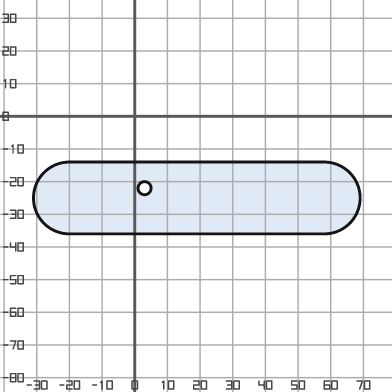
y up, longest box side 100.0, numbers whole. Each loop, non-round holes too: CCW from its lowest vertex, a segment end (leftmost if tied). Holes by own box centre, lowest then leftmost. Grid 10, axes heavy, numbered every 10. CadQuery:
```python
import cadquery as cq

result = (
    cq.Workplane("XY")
    .moveTo(-20.0, -36.0)
    .lineTo(58.0, -36.0)
    .threePointArc((69.0, -25.0), (58.0, -14.0))
    .lineTo(-20.0, -14.0)
    .threePointArc((-31.0, -25.0), (-20.0, -36.0))
    .close()
    .moveTo(3.0, -22.0)
    .circle(2.0)
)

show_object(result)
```